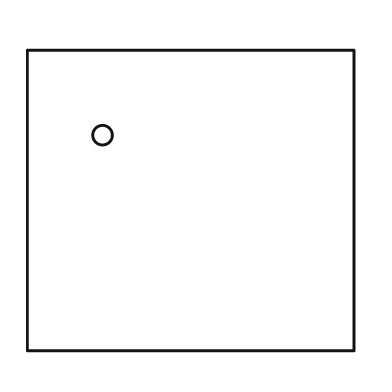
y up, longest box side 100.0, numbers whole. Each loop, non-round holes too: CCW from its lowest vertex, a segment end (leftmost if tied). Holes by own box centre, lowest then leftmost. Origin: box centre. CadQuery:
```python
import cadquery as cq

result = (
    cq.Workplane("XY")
    .moveTo(-50.0, -46.0)
    .lineTo(50.0, -46.0)
    .lineTo(50.0, 46.0)
    .lineTo(-50.0, 46.0)
    .close()
    .moveTo(-27.0, 20.0)
    .circle(3.0)
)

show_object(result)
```